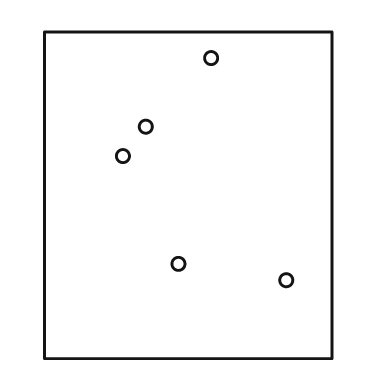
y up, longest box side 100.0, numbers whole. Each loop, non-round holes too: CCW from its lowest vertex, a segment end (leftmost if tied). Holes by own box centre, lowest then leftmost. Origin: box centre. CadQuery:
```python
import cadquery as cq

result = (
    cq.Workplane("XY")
    .moveTo(-44.0, -50.0)
    .lineTo(44.0, -50.0)
    .lineTo(44.0, 50.0)
    .lineTo(-44.0, 50.0)
    .close()
    .moveTo(30.0, -26.0)
    .circle(2.0)
    .moveTo(-3.0, -21.0)
    .circle(2.0)
    .moveTo(-20.0, 12.0)
    .circle(2.0)
    .moveTo(-13.0, 21.0)
    .circle(2.0)
    .moveTo(7.0, 42.0)
    .circle(2.0)
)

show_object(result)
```